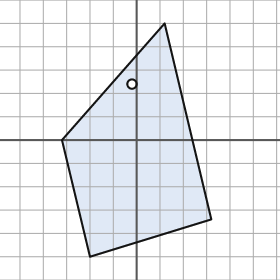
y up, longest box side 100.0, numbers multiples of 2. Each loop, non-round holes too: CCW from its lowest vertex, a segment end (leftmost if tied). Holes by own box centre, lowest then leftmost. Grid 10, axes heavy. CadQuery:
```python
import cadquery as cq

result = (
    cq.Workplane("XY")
    .moveTo(-20.0, -50.0)
    .lineTo(32.0, -34.0)
    .lineTo(12.0, 50.0)
    .lineTo(-32.0, 0.0)
    .close()
    .moveTo(-2.0, 24.0)
    .circle(2.0)
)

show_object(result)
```